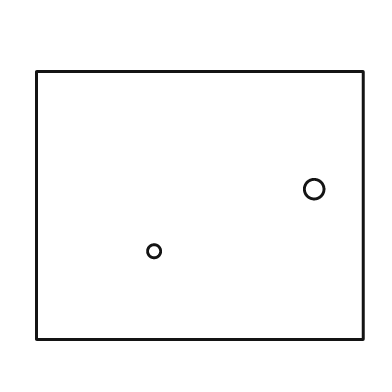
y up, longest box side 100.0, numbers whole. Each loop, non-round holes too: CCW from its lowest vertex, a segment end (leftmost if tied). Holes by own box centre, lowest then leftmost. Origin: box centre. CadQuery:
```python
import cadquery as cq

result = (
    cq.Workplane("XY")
    .moveTo(-50.0, -41.0)
    .lineTo(50.0, -41.0)
    .lineTo(50.0, 41.0)
    .lineTo(-50.0, 41.0)
    .close()
    .moveTo(-14.0, -14.0)
    .circle(2.0)
    .moveTo(35.0, 5.0)
    .circle(3.0)
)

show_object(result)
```